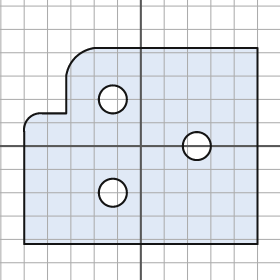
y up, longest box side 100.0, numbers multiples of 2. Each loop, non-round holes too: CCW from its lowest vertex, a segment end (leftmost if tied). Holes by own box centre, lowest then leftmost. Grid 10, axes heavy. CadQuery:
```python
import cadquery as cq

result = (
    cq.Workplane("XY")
    .moveTo(-50.0, -42.0)
    .lineTo(50.0, -42.0)
    .lineTo(50.0, 42.0)
    .lineTo(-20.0, 42.0)
    .threePointArc((-28.0, 38.0), (-32.0, 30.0))
    .lineTo(-32.0, 14.0)
    .lineTo(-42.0, 14.0)
    .threePointArc((-48.0, 12.0), (-50.0, 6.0))
    .close()
    .moveTo(-12.0, -20.0)
    .circle(6.0)
    .moveTo(24.0, 0.0)
    .circle(6.0)
    .moveTo(-12.0, 20.0)
    .circle(6.0)
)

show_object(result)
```